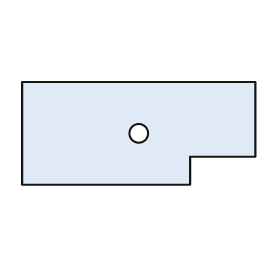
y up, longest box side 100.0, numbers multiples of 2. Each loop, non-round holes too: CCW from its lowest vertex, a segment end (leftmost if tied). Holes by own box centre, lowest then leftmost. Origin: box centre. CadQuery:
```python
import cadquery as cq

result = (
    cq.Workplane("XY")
    .moveTo(-50.0, -22.0)
    .lineTo(22.0, -22.0)
    .lineTo(22.0, -10.0)
    .lineTo(50.0, -10.0)
    .lineTo(50.0, 22.0)
    .lineTo(-50.0, 22.0)
    .close()
    .moveTo(0.0, 0.0)
    .circle(4.0)
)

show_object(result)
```